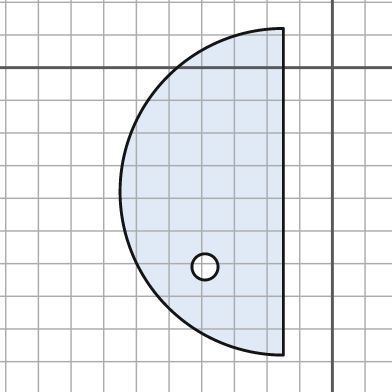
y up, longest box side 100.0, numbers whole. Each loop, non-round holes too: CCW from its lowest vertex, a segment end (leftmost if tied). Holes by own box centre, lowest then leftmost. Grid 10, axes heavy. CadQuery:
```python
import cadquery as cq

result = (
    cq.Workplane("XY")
    .moveTo(-15.0, -88.0)
    .lineTo(-15.0, 12.0)
    .threePointArc((-65.0, -38.0), (-15.0, -88.0))
    .close()
    .moveTo(-39.0, -61.0)
    .circle(4.0)
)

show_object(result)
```